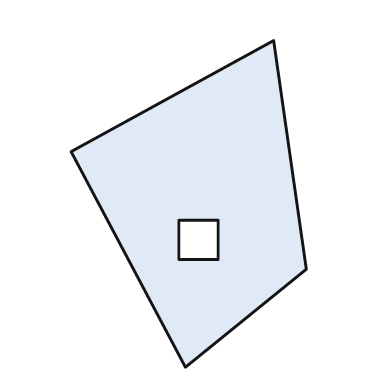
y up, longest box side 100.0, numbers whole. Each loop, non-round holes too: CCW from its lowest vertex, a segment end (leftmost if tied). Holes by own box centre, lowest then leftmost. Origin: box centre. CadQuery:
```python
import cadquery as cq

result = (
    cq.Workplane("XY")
    .moveTo(-1.0, -50.0)
    .lineTo(36.0, -20.0)
    .lineTo(26.0, 50.0)
    .lineTo(-36.0, 16.0)
    .close()
    .moveTo(-3.0, -17.0)
    .lineTo(9.0, -17.0)
    .lineTo(9.0, -5.0)
    .lineTo(-3.0, -5.0)
    .close()
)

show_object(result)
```